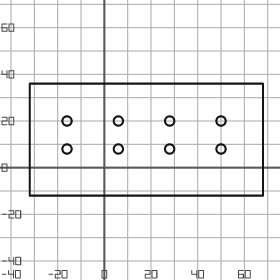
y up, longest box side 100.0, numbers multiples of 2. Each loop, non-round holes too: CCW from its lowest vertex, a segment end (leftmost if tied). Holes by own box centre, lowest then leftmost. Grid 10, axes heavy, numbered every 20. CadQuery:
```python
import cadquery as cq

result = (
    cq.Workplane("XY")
    .moveTo(-32.0, -12.0)
    .lineTo(68.0, -12.0)
    .lineTo(68.0, 36.0)
    .lineTo(-32.0, 36.0)
    .close()
    .moveTo(-16.0, 8.0)
    .circle(2.0)
    .moveTo(6.0, 8.0)
    .circle(2.0)
    .moveTo(28.0, 8.0)
    .circle(2.0)
    .moveTo(50.0, 8.0)
    .circle(2.0)
    .moveTo(-16.0, 20.0)
    .circle(2.0)
    .moveTo(6.0, 20.0)
    .circle(2.0)
    .moveTo(28.0, 20.0)
    .circle(2.0)
    .moveTo(50.0, 20.0)
    .circle(2.0)
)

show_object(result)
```